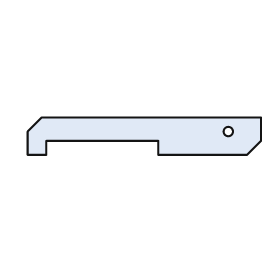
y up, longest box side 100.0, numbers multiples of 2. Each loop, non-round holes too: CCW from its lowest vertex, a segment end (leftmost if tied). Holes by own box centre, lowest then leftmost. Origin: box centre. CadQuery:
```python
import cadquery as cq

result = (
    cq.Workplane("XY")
    .moveTo(-50.0, -8.0)
    .lineTo(-42.0, -8.0)
    .lineTo(-42.0, -2.0)
    .lineTo(6.0, -2.0)
    .lineTo(6.0, -8.0)
    .lineTo(44.0, -8.0)
    .lineTo(50.0, -2.0)
    .lineTo(50.0, 8.0)
    .lineTo(-44.0, 8.0)
    .lineTo(-50.0, 2.0)
    .close()
    .moveTo(36.0, 2.0)
    .circle(2.0)
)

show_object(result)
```